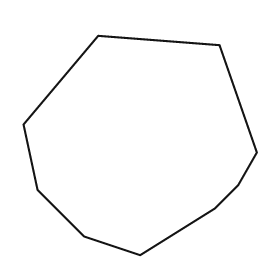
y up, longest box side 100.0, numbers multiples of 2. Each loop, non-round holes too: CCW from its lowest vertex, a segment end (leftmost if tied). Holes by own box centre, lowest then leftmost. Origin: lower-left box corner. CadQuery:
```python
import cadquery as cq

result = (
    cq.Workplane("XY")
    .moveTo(50.0, 0.0)
    .lineTo(82.0, 20.0)
    .lineTo(92.0, 30.0)
    .lineTo(100.0, 44.0)
    .lineTo(84.0, 90.0)
    .lineTo(32.0, 94.0)
    .lineTo(0.0, 56.0)
    .lineTo(6.0, 28.0)
    .lineTo(26.0, 8.0)
    .close()
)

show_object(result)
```